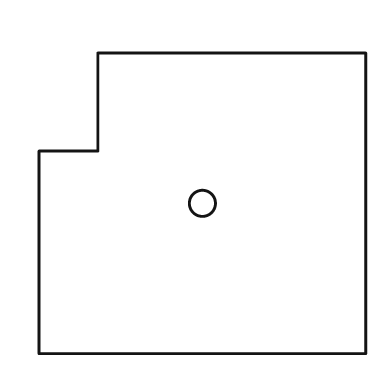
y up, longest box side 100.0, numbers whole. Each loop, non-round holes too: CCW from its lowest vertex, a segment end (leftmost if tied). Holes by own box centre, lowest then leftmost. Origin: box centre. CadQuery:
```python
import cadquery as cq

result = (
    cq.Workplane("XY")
    .moveTo(-50.0, -46.0)
    .lineTo(50.0, -46.0)
    .lineTo(50.0, 46.0)
    .lineTo(-32.0, 46.0)
    .lineTo(-32.0, 16.0)
    .lineTo(-50.0, 16.0)
    .close()
    .moveTo(0.0, 0.0)
    .circle(4.0)
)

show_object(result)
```